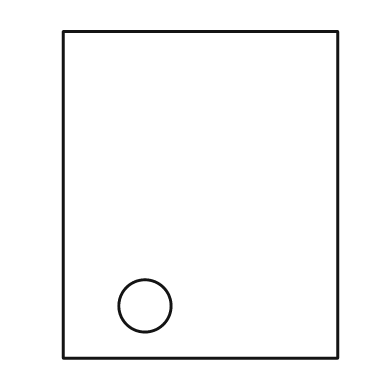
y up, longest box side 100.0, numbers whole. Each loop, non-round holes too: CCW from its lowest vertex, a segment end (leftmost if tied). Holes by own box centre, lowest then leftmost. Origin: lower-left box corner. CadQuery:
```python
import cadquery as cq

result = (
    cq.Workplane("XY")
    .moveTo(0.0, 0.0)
    .lineTo(84.0, 0.0)
    .lineTo(84.0, 100.0)
    .lineTo(0.0, 100.0)
    .close()
    .moveTo(25.0, 16.0)
    .circle(8.0)
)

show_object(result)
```